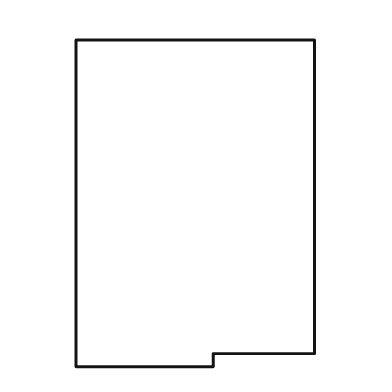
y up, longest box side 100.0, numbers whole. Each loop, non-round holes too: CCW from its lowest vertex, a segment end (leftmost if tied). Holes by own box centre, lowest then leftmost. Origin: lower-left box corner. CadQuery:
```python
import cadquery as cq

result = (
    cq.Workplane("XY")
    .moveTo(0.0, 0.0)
    .lineTo(42.0, 0.0)
    .lineTo(42.0, 4.0)
    .lineTo(73.0, 4.0)
    .lineTo(73.0, 100.0)
    .lineTo(0.0, 100.0)
    .close()
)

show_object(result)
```